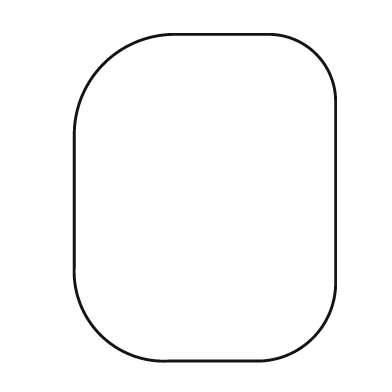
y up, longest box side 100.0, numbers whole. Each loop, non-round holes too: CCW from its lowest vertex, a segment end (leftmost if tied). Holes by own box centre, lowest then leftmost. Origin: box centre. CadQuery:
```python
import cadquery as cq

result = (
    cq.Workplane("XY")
    .moveTo(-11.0, -50.0)
    .lineTo(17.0, -50.0)
    .threePointArc((33.0, -43.0), (40.0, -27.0))
    .lineTo(40.0, 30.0)
    .threePointArc((34.0, 44.0), (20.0, 50.0))
    .lineTo(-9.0, 50.0)
    .threePointArc((-31.0, 41.0), (-40.0, 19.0))
    .lineTo(-40.0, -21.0)
    .threePointArc((-32.0, -42.0), (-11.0, -50.0))
    .close()
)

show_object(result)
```